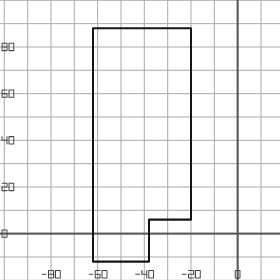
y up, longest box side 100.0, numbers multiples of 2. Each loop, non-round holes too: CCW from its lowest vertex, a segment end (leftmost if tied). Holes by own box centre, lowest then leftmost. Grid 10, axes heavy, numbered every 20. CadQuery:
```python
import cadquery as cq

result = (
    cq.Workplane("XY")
    .moveTo(-62.0, -12.0)
    .lineTo(-38.0, -12.0)
    .lineTo(-38.0, 6.0)
    .lineTo(-20.0, 6.0)
    .lineTo(-20.0, 88.0)
    .lineTo(-62.0, 88.0)
    .close()
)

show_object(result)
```